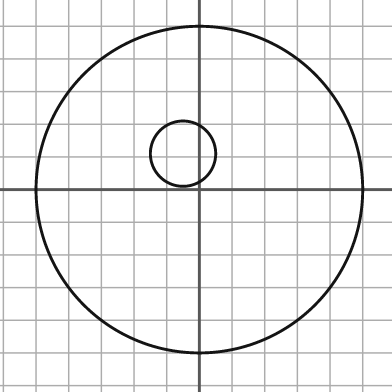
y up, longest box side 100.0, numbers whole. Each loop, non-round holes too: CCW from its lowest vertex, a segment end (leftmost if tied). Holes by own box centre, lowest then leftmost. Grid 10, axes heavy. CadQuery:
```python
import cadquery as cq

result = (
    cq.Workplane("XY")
    .moveTo(0.0, 0.0)
    .circle(50.0)
    .moveTo(-5.0, 11.0)
    .circle(10.0)
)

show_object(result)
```